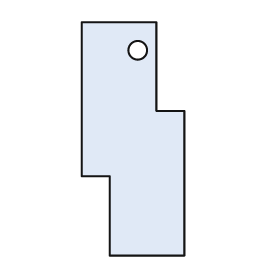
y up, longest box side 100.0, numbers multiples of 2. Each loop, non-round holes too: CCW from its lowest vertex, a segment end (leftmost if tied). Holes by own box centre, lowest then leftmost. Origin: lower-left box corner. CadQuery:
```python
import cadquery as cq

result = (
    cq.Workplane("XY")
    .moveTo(12.0, 0.0)
    .lineTo(44.0, 0.0)
    .lineTo(44.0, 62.0)
    .lineTo(32.0, 62.0)
    .lineTo(32.0, 100.0)
    .lineTo(0.0, 100.0)
    .lineTo(0.0, 34.0)
    .lineTo(12.0, 34.0)
    .close()
    .moveTo(24.0, 88.0)
    .circle(4.0)
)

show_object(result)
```